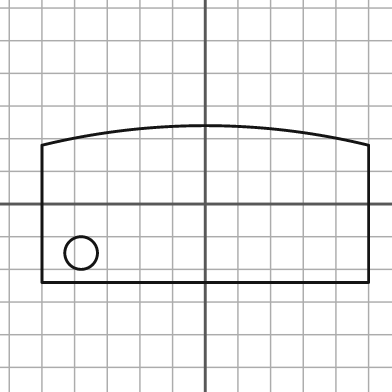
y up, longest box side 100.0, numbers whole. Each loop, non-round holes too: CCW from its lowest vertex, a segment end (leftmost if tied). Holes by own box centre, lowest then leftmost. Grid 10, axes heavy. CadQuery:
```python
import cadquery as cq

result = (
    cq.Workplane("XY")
    .moveTo(-50.0, -24.0)
    .lineTo(50.0, -24.0)
    .lineTo(50.0, 18.0)
    .threePointArc((0.0, 24.0), (-50.0, 18.0))
    .close()
    .moveTo(-38.0, -15.0)
    .circle(5.0)
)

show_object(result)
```